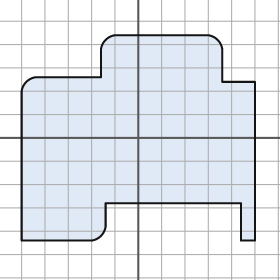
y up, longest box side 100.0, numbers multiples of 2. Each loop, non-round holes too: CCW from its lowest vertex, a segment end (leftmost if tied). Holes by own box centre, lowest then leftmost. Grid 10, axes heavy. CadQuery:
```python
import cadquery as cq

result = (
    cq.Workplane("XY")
    .moveTo(-50.0, -44.0)
    .lineTo(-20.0, -44.0)
    .threePointArc((-16.0, -42.0), (-14.0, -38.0))
    .lineTo(-14.0, -28.0)
    .lineTo(44.0, -28.0)
    .lineTo(44.0, -44.0)
    .lineTo(50.0, -44.0)
    .lineTo(50.0, 24.0)
    .lineTo(36.0, 24.0)
    .lineTo(36.0, 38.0)
    .threePointArc((34.0, 42.0), (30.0, 44.0))
    .lineTo(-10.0, 44.0)
    .threePointArc((-14.0, 42.0), (-16.0, 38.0))
    .lineTo(-16.0, 26.0)
    .lineTo(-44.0, 26.0)
    .threePointArc((-48.0, 24.0), (-50.0, 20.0))
    .close()
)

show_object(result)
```